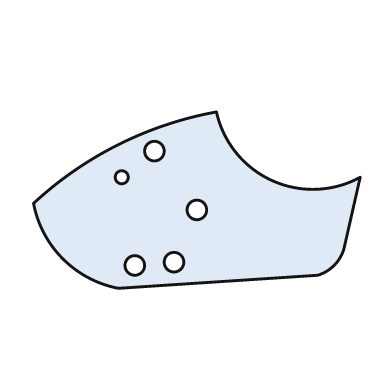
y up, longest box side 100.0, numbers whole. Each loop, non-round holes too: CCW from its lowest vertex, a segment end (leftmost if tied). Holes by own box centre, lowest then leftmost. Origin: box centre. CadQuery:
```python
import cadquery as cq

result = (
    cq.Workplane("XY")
    .moveTo(-24.0, -27.0)
    .lineTo(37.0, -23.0)
    .threePointArc((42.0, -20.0), (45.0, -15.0))
    .lineTo(50.0, 7.0)
    .threePointArc((23.0, 6.0), (6.0, 27.0))
    .threePointArc((-24.0, 17.0), (-50.0, -1.0))
    .threePointArc((-41.0, -18.0), (-24.0, -27.0))
    .close()
    .moveTo(-19.0, -20.0)
    .circle(3.0)
    .moveTo(-7.0, -19.0)
    .circle(3.0)
    .moveTo(0.0, -3.0)
    .circle(3.0)
    .moveTo(-23.0, 7.0)
    .circle(2.0)
    .moveTo(-13.0, 15.0)
    .circle(3.0)
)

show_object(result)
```